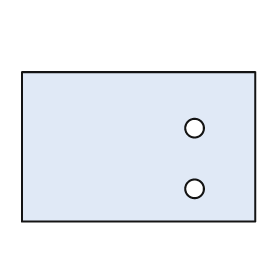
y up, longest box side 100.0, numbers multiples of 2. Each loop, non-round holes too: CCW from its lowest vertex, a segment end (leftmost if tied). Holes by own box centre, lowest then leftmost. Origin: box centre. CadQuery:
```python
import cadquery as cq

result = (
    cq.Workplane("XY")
    .moveTo(-50.0, -32.0)
    .lineTo(50.0, -32.0)
    .lineTo(50.0, 32.0)
    .lineTo(-50.0, 32.0)
    .close()
    .moveTo(24.0, -18.0)
    .circle(4.0)
    .moveTo(24.0, 8.0)
    .circle(4.0)
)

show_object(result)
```